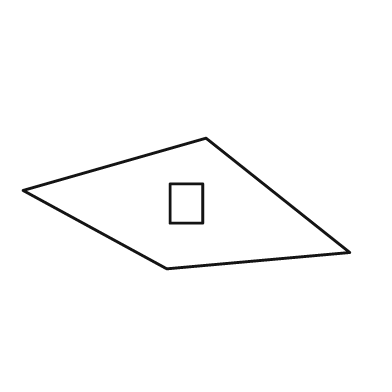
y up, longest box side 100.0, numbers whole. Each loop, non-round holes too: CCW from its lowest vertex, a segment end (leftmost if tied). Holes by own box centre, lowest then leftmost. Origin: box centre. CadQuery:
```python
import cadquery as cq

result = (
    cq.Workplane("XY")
    .moveTo(-6.0, -20.0)
    .lineTo(50.0, -15.0)
    .lineTo(6.0, 20.0)
    .lineTo(-50.0, 4.0)
    .close()
    .moveTo(-5.0, -6.0)
    .lineTo(5.0, -6.0)
    .lineTo(5.0, 6.0)
    .lineTo(-5.0, 6.0)
    .close()
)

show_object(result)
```